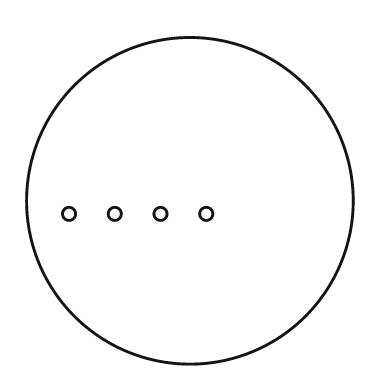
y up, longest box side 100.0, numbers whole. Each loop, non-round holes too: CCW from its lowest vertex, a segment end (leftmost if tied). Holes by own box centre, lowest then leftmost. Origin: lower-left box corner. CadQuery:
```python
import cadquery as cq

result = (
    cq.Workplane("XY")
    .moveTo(50.0, 50.0)
    .circle(50.0)
    .moveTo(13.0, 46.0)
    .circle(2.0)
    .moveTo(27.0, 46.0)
    .circle(2.0)
    .moveTo(41.0, 46.0)
    .circle(2.0)
    .moveTo(55.0, 46.0)
    .circle(2.0)
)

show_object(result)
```